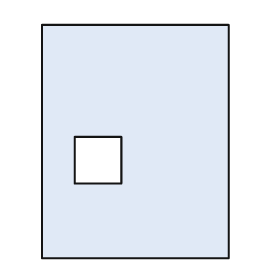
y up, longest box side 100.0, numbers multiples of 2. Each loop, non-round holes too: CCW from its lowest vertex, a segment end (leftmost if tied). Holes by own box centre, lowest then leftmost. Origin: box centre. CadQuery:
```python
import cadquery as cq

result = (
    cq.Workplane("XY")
    .moveTo(-40.0, -50.0)
    .lineTo(40.0, -50.0)
    .lineTo(40.0, 50.0)
    .lineTo(-40.0, 50.0)
    .close()
    .moveTo(-26.0, -18.0)
    .lineTo(-6.0, -18.0)
    .lineTo(-6.0, 2.0)
    .lineTo(-26.0, 2.0)
    .close()
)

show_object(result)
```